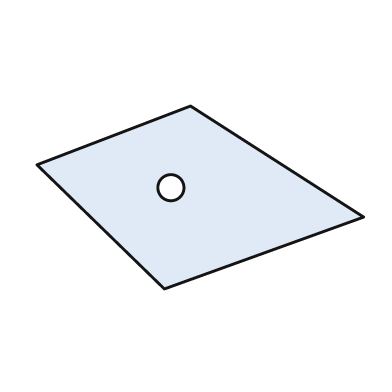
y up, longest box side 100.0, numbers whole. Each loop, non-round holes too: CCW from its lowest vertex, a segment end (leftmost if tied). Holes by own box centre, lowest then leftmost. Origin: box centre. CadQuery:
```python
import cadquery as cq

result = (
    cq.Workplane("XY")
    .moveTo(-11.0, -28.0)
    .lineTo(50.0, -6.0)
    .lineTo(-3.0, 28.0)
    .lineTo(-50.0, 10.0)
    .close()
    .moveTo(-9.0, 3.0)
    .circle(4.0)
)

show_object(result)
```